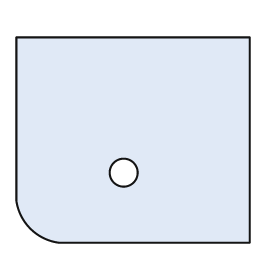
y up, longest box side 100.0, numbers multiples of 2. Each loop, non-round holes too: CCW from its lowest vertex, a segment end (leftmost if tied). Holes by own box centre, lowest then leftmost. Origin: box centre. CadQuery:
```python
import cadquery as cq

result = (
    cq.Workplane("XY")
    .moveTo(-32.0, -44.0)
    .lineTo(50.0, -44.0)
    .lineTo(50.0, 44.0)
    .lineTo(-50.0, 44.0)
    .lineTo(-50.0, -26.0)
    .threePointArc((-44.0, -38.0), (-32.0, -44.0))
    .close()
    .moveTo(-4.0, -14.0)
    .circle(6.0)
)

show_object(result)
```